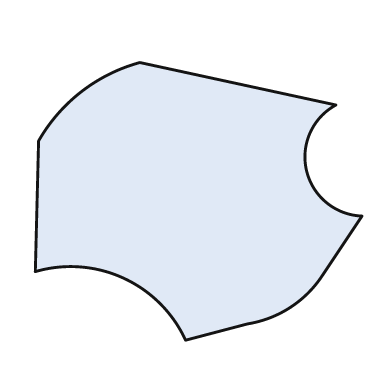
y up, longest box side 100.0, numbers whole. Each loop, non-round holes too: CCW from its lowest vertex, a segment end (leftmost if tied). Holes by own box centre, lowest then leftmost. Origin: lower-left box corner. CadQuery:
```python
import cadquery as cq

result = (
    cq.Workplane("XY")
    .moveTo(46.0, 0.0)
    .lineTo(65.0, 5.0)
    .threePointArc((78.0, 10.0), (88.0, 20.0))
    .lineTo(100.0, 38.0)
    .threePointArc((83.0, 52.0), (92.0, 72.0))
    .lineTo(32.0, 85.0)
    .threePointArc((14.0, 76.0), (1.0, 61.0))
    .lineTo(0.0, 21.0)
    .threePointArc((27.0, 19.0), (46.0, 0.0))
    .close()
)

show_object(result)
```